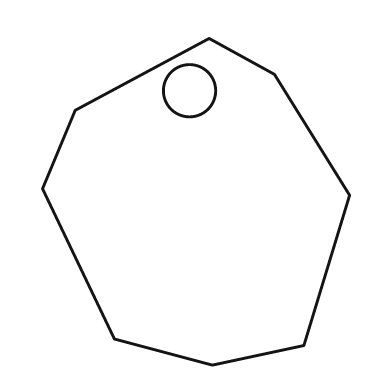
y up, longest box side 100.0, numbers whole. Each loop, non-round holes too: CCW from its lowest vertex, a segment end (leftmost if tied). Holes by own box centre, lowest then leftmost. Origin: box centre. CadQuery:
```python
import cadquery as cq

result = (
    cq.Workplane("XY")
    .moveTo(5.0, -50.0)
    .lineTo(33.0, -44.0)
    .lineTo(47.0, 2.0)
    .lineTo(24.0, 39.0)
    .lineTo(4.0, 50.0)
    .lineTo(-37.0, 28.0)
    .lineTo(-47.0, 4.0)
    .lineTo(-25.0, -42.0)
    .close()
    .moveTo(-2.0, 34.0)
    .circle(8.0)
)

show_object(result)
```